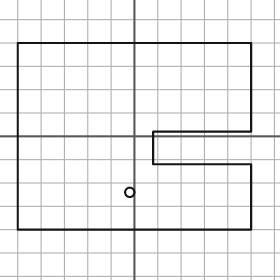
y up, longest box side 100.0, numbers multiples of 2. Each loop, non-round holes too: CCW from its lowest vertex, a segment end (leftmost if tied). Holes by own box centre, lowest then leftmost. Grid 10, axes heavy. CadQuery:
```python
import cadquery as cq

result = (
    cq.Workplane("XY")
    .moveTo(-50.0, -40.0)
    .lineTo(50.0, -40.0)
    .lineTo(50.0, -12.0)
    .lineTo(8.0, -12.0)
    .lineTo(8.0, 2.0)
    .lineTo(50.0, 2.0)
    .lineTo(50.0, 40.0)
    .lineTo(-50.0, 40.0)
    .close()
    .moveTo(-2.0, -24.0)
    .circle(2.0)
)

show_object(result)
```